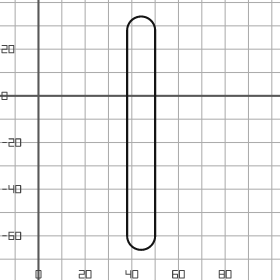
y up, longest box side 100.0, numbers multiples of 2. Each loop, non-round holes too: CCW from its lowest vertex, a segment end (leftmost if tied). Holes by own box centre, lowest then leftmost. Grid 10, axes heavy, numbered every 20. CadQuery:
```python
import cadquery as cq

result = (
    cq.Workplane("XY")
    .moveTo(38.0, -60.0)
    .threePointArc((44.0, -66.0), (50.0, -60.0))
    .lineTo(50.0, 28.0)
    .threePointArc((44.0, 34.0), (38.0, 28.0))
    .close()
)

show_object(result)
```